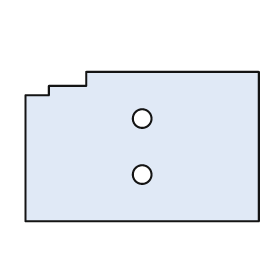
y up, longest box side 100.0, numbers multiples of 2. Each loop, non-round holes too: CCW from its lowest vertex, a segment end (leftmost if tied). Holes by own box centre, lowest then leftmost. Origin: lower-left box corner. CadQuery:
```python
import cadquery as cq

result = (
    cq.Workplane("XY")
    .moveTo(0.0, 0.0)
    .lineTo(100.0, 0.0)
    .lineTo(100.0, 64.0)
    .lineTo(26.0, 64.0)
    .lineTo(26.0, 58.0)
    .lineTo(10.0, 58.0)
    .lineTo(10.0, 54.0)
    .lineTo(0.0, 54.0)
    .close()
    .moveTo(50.0, 20.0)
    .circle(4.0)
    .moveTo(50.0, 44.0)
    .circle(4.0)
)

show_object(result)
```